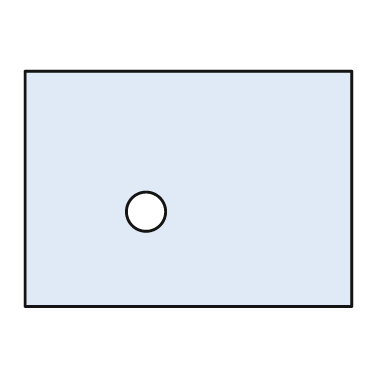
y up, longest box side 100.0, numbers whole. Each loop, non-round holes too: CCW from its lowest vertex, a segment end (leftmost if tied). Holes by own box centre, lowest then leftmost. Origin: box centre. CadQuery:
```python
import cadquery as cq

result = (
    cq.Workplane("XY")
    .moveTo(-50.0, -36.0)
    .lineTo(50.0, -36.0)
    .lineTo(50.0, 36.0)
    .lineTo(-50.0, 36.0)
    .close()
    .moveTo(-13.0, -7.0)
    .circle(6.0)
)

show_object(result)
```